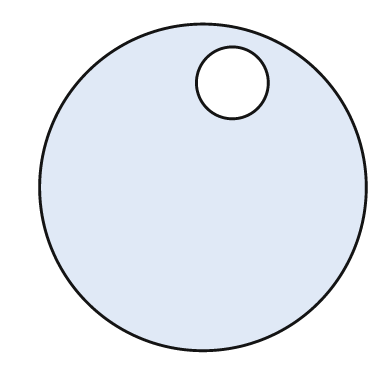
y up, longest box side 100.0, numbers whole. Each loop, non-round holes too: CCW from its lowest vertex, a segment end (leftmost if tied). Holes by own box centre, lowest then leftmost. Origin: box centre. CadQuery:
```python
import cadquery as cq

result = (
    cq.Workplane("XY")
    .moveTo(0.0, 0.0)
    .circle(50.0)
    .moveTo(9.0, 32.0)
    .circle(11.0)
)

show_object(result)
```